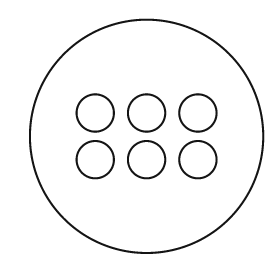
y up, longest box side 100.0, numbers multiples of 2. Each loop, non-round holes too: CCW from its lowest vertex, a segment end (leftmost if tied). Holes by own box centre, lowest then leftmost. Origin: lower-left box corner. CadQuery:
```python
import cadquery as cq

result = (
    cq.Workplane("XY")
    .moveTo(50.0, 50.0)
    .circle(50.0)
    .moveTo(28.0, 40.0)
    .circle(8.0)
    .moveTo(50.0, 40.0)
    .circle(8.0)
    .moveTo(72.0, 40.0)
    .circle(8.0)
    .moveTo(28.0, 60.0)
    .circle(8.0)
    .moveTo(50.0, 60.0)
    .circle(8.0)
    .moveTo(72.0, 60.0)
    .circle(8.0)
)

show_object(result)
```